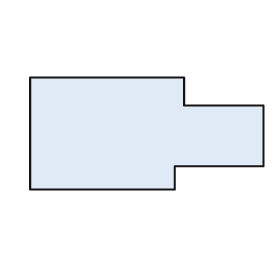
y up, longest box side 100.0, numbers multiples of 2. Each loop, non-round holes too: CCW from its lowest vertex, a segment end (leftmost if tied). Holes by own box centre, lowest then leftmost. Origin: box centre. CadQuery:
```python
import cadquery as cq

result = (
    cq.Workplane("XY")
    .moveTo(-50.0, -24.0)
    .lineTo(12.0, -24.0)
    .lineTo(12.0, -14.0)
    .lineTo(50.0, -14.0)
    .lineTo(50.0, 12.0)
    .lineTo(16.0, 12.0)
    .lineTo(16.0, 24.0)
    .lineTo(-50.0, 24.0)
    .close()
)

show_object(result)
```